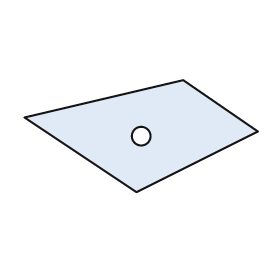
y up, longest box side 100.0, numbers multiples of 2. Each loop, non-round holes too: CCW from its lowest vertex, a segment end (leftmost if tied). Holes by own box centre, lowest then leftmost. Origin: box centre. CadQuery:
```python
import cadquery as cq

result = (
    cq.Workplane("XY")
    .moveTo(-2.0, -24.0)
    .lineTo(50.0, 2.0)
    .lineTo(18.0, 24.0)
    .lineTo(-50.0, 8.0)
    .close()
    .moveTo(0.0, 0.0)
    .circle(4.0)
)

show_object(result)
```